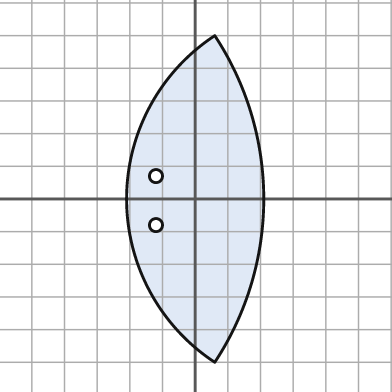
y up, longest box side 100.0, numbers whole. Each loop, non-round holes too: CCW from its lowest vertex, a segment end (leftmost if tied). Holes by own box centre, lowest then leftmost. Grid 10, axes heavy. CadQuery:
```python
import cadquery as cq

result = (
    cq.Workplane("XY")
    .moveTo(6.0, -50.0)
    .threePointArc((21.0, 0.0), (6.0, 50.0))
    .threePointArc((-21.0, 0.0), (6.0, -50.0))
    .close()
    .moveTo(-12.0, -8.0)
    .circle(2.0)
    .moveTo(-12.0, 7.0)
    .circle(2.0)
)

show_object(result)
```